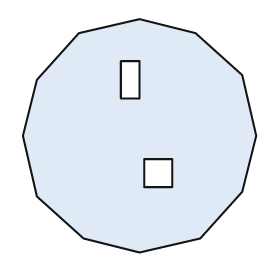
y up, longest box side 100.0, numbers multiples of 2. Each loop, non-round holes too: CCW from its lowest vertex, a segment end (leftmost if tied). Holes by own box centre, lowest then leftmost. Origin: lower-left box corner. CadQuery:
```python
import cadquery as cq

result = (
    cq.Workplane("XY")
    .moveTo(50.0, 0.0)
    .lineTo(76.0, 6.0)
    .lineTo(94.0, 26.0)
    .lineTo(100.0, 50.0)
    .lineTo(94.0, 76.0)
    .lineTo(74.0, 94.0)
    .lineTo(50.0, 100.0)
    .lineTo(24.0, 94.0)
    .lineTo(6.0, 74.0)
    .lineTo(0.0, 50.0)
    .lineTo(6.0, 24.0)
    .lineTo(26.0, 6.0)
    .close()
    .moveTo(52.0, 28.0)
    .lineTo(64.0, 28.0)
    .lineTo(64.0, 40.0)
    .lineTo(52.0, 40.0)
    .close()
    .moveTo(42.0, 66.0)
    .lineTo(50.0, 66.0)
    .lineTo(50.0, 82.0)
    .lineTo(42.0, 82.0)
    .close()
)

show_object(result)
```